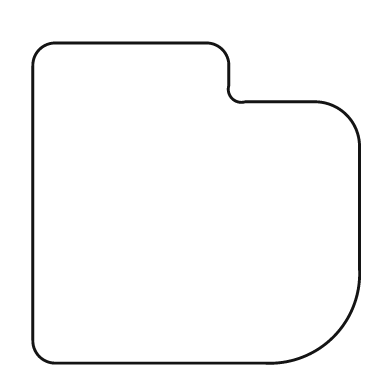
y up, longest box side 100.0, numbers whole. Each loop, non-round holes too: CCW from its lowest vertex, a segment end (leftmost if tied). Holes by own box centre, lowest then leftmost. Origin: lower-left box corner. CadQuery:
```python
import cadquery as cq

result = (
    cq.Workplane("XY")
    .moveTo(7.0, 0.0)
    .lineTo(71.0, 0.0)
    .threePointArc((92.0, 8.0), (100.0, 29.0))
    .lineTo(100.0, 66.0)
    .threePointArc((96.0, 76.0), (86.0, 80.0))
    .lineTo(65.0, 80.0)
    .threePointArc((61.0, 81.0), (60.0, 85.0))
    .lineTo(60.0, 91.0)
    .threePointArc((58.0, 96.0), (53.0, 98.0))
    .lineTo(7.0, 98.0)
    .threePointArc((2.0, 96.0), (0.0, 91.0))
    .lineTo(0.0, 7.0)
    .threePointArc((2.0, 2.0), (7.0, 0.0))
    .close()
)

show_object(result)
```